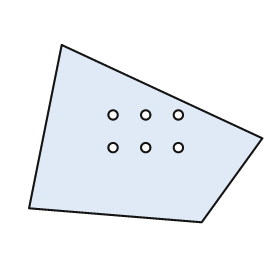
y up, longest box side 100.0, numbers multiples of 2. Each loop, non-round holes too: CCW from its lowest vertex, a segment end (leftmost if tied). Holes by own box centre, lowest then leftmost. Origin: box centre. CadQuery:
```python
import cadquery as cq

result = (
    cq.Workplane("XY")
    .moveTo(24.0, -38.0)
    .lineTo(50.0, -2.0)
    .lineTo(-36.0, 38.0)
    .lineTo(-50.0, -32.0)
    .close()
    .moveTo(-14.0, -6.0)
    .circle(2.0)
    .moveTo(0.0, -6.0)
    .circle(2.0)
    .moveTo(14.0, -6.0)
    .circle(2.0)
    .moveTo(-14.0, 8.0)
    .circle(2.0)
    .moveTo(0.0, 8.0)
    .circle(2.0)
    .moveTo(14.0, 8.0)
    .circle(2.0)
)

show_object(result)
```